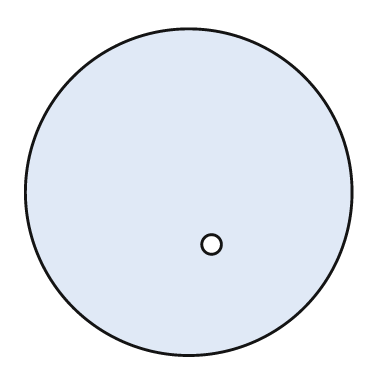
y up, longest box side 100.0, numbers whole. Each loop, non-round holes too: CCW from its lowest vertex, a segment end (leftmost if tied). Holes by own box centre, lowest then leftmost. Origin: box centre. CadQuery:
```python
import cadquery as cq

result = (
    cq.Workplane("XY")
    .moveTo(0.0, 0.0)
    .circle(50.0)
    .moveTo(7.0, -16.0)
    .circle(3.0)
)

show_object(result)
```